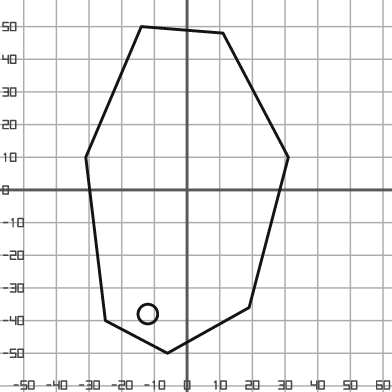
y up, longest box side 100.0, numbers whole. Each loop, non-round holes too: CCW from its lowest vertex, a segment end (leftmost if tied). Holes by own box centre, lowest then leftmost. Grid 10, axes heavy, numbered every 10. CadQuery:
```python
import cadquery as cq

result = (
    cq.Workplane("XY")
    .moveTo(-6.0, -50.0)
    .lineTo(19.0, -36.0)
    .lineTo(31.0, 10.0)
    .lineTo(11.0, 48.0)
    .lineTo(-14.0, 50.0)
    .lineTo(-31.0, 10.0)
    .lineTo(-25.0, -40.0)
    .close()
    .moveTo(-12.0, -38.0)
    .circle(3.0)
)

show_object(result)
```